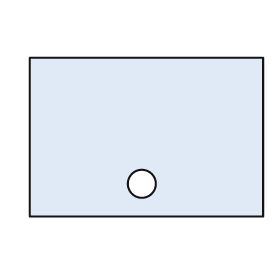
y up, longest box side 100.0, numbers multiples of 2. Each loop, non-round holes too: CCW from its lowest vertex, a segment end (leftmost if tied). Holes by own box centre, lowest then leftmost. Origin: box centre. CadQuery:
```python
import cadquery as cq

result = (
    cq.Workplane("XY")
    .moveTo(-50.0, -34.0)
    .lineTo(50.0, -34.0)
    .lineTo(50.0, 34.0)
    .lineTo(-50.0, 34.0)
    .close()
    .moveTo(-2.0, -20.0)
    .circle(6.0)
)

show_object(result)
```